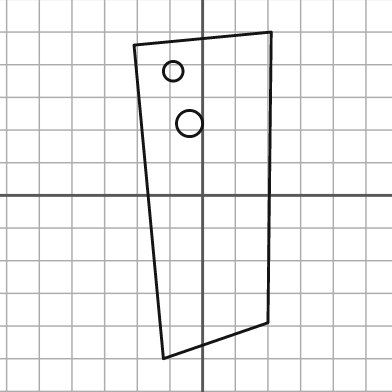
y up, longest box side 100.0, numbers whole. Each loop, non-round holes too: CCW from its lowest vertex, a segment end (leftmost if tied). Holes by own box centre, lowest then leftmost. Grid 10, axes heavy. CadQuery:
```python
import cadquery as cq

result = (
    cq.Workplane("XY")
    .moveTo(-12.0, -50.0)
    .lineTo(20.0, -39.0)
    .lineTo(21.0, 50.0)
    .lineTo(-21.0, 46.0)
    .close()
    .moveTo(-4.0, 22.0)
    .circle(4.0)
    .moveTo(-9.0, 38.0)
    .circle(3.0)
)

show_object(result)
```